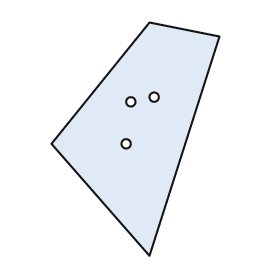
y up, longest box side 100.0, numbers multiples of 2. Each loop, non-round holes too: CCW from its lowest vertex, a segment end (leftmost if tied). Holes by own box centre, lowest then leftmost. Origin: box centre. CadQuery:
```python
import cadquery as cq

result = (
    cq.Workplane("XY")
    .moveTo(6.0, -50.0)
    .lineTo(36.0, 44.0)
    .lineTo(6.0, 50.0)
    .lineTo(-36.0, -2.0)
    .close()
    .moveTo(-4.0, -2.0)
    .circle(2.0)
    .moveTo(-2.0, 16.0)
    .circle(2.0)
    .moveTo(8.0, 18.0)
    .circle(2.0)
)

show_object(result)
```